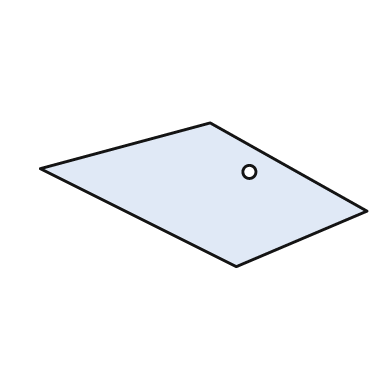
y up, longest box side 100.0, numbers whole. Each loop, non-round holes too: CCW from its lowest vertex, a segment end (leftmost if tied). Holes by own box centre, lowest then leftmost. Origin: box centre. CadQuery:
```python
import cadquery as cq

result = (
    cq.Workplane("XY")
    .moveTo(10.0, -22.0)
    .lineTo(50.0, -5.0)
    .lineTo(2.0, 22.0)
    .lineTo(-50.0, 8.0)
    .close()
    .moveTo(14.0, 7.0)
    .circle(2.0)
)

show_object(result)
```